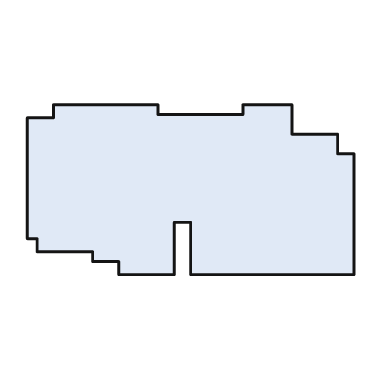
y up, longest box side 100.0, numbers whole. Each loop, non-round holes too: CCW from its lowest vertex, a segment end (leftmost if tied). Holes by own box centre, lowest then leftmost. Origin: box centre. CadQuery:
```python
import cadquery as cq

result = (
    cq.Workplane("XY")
    .moveTo(-22.0, -26.0)
    .lineTo(-5.0, -26.0)
    .lineTo(-5.0, -10.0)
    .lineTo(0.0, -10.0)
    .lineTo(0.0, -26.0)
    .lineTo(50.0, -26.0)
    .lineTo(50.0, 11.0)
    .lineTo(45.0, 11.0)
    .lineTo(45.0, 17.0)
    .lineTo(31.0, 17.0)
    .lineTo(31.0, 26.0)
    .lineTo(16.0, 26.0)
    .lineTo(16.0, 23.0)
    .lineTo(-10.0, 23.0)
    .lineTo(-10.0, 26.0)
    .lineTo(-42.0, 26.0)
    .lineTo(-42.0, 22.0)
    .lineTo(-50.0, 22.0)
    .lineTo(-50.0, -15.0)
    .lineTo(-47.0, -15.0)
    .lineTo(-47.0, -19.0)
    .lineTo(-30.0, -19.0)
    .lineTo(-30.0, -22.0)
    .lineTo(-22.0, -22.0)
    .close()
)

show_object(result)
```